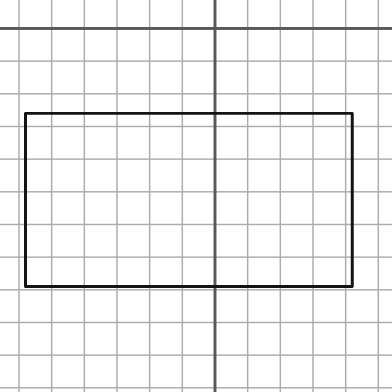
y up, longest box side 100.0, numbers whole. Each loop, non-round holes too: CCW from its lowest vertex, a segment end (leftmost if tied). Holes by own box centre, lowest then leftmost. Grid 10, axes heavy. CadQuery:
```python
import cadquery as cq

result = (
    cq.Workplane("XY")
    .moveTo(-58.0, -79.0)
    .lineTo(42.0, -79.0)
    .lineTo(42.0, -26.0)
    .lineTo(-58.0, -26.0)
    .close()
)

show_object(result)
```